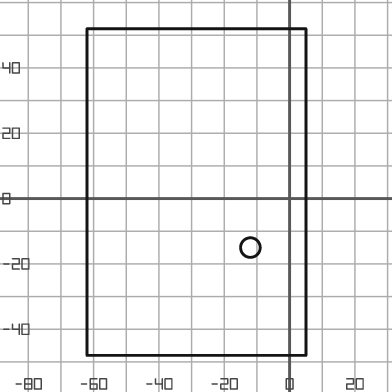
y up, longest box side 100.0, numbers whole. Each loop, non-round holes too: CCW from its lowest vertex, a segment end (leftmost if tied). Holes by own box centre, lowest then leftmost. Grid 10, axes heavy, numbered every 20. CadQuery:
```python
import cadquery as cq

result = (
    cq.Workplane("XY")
    .moveTo(-62.0, -48.0)
    .lineTo(5.0, -48.0)
    .lineTo(5.0, 52.0)
    .lineTo(-62.0, 52.0)
    .close()
    .moveTo(-12.0, -15.0)
    .circle(3.0)
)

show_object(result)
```